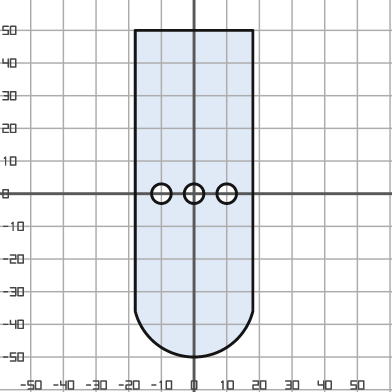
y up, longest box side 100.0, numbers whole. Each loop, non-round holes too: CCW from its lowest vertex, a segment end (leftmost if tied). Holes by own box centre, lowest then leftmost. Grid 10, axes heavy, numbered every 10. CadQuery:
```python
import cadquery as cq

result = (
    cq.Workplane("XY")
    .moveTo(-18.0, -36.0)
    .threePointArc((0.0, -50.0), (18.0, -36.0))
    .lineTo(18.0, 50.0)
    .lineTo(-18.0, 50.0)
    .close()
    .moveTo(-10.0, 0.0)
    .circle(3.0)
    .moveTo(0.0, 0.0)
    .circle(3.0)
    .moveTo(10.0, 0.0)
    .circle(3.0)
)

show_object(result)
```